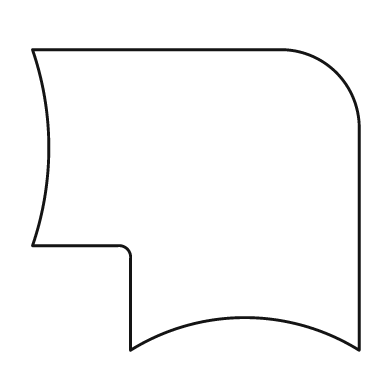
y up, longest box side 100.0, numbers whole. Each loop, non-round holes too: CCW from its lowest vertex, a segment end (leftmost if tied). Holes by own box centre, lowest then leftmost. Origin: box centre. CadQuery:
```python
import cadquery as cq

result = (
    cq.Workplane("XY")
    .moveTo(-20.0, -46.0)
    .threePointArc((15.0, -36.0), (50.0, -46.0))
    .lineTo(50.0, 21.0)
    .threePointArc((43.0, 39.0), (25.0, 46.0))
    .lineTo(-50.0, 46.0)
    .threePointArc((-45.0, 16.0), (-50.0, -14.0))
    .lineTo(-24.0, -14.0)
    .threePointArc((-21.0, -15.0), (-20.0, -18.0))
    .close()
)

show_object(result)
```